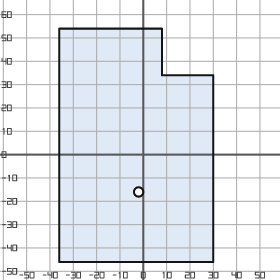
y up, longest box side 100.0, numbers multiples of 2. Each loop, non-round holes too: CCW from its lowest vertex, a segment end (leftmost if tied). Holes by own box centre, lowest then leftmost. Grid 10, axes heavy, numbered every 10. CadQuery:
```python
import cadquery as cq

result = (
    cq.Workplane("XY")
    .moveTo(-36.0, -46.0)
    .lineTo(30.0, -46.0)
    .lineTo(30.0, 34.0)
    .lineTo(8.0, 34.0)
    .lineTo(8.0, 54.0)
    .lineTo(-36.0, 54.0)
    .close()
    .moveTo(-2.0, -16.0)
    .circle(2.0)
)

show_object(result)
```